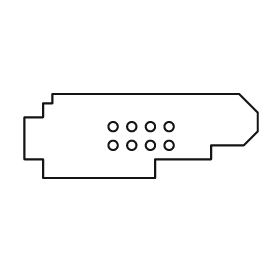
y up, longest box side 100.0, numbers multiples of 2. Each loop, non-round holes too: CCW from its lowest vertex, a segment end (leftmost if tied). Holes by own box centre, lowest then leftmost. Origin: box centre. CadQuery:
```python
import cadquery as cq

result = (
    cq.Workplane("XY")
    .moveTo(-42.0, -18.0)
    .lineTo(6.0, -18.0)
    .lineTo(6.0, -10.0)
    .lineTo(30.0, -10.0)
    .lineTo(30.0, -4.0)
    .lineTo(44.0, -4.0)
    .lineTo(50.0, 2.0)
    .lineTo(50.0, 10.0)
    .lineTo(42.0, 18.0)
    .lineTo(-38.0, 18.0)
    .lineTo(-38.0, 14.0)
    .lineTo(-42.0, 14.0)
    .lineTo(-42.0, 8.0)
    .lineTo(-50.0, 8.0)
    .lineTo(-50.0, -10.0)
    .lineTo(-42.0, -10.0)
    .close()
    .moveTo(-12.0, -4.0)
    .circle(2.0)
    .moveTo(-4.0, -4.0)
    .circle(2.0)
    .moveTo(4.0, -4.0)
    .circle(2.0)
    .moveTo(12.0, -4.0)
    .circle(2.0)
    .moveTo(-12.0, 4.0)
    .circle(2.0)
    .moveTo(-4.0, 4.0)
    .circle(2.0)
    .moveTo(4.0, 4.0)
    .circle(2.0)
    .moveTo(12.0, 4.0)
    .circle(2.0)
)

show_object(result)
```